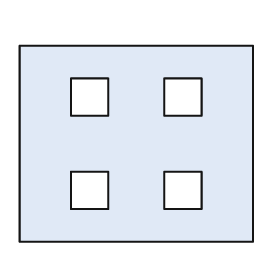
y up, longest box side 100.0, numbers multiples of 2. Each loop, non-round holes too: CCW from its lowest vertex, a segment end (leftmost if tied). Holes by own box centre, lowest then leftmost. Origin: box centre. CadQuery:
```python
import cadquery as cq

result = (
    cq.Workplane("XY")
    .moveTo(-50.0, -42.0)
    .lineTo(50.0, -42.0)
    .lineTo(50.0, 42.0)
    .lineTo(-50.0, 42.0)
    .close()
    .moveTo(-28.0, -28.0)
    .lineTo(-12.0, -28.0)
    .lineTo(-12.0, -12.0)
    .lineTo(-28.0, -12.0)
    .close()
    .moveTo(12.0, -28.0)
    .lineTo(28.0, -28.0)
    .lineTo(28.0, -12.0)
    .lineTo(12.0, -12.0)
    .close()
    .moveTo(-28.0, 12.0)
    .lineTo(-12.0, 12.0)
    .lineTo(-12.0, 28.0)
    .lineTo(-28.0, 28.0)
    .close()
    .moveTo(12.0, 12.0)
    .lineTo(28.0, 12.0)
    .lineTo(28.0, 28.0)
    .lineTo(12.0, 28.0)
    .close()
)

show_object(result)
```